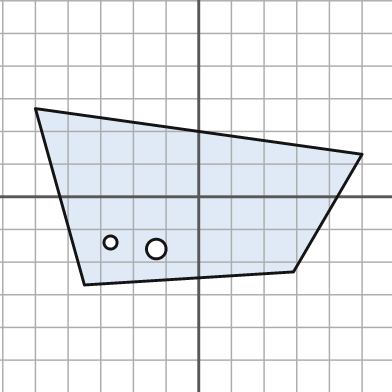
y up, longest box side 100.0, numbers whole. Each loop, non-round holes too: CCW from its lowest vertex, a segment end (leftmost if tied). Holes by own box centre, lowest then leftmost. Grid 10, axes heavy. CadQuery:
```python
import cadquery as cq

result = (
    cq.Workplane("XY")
    .moveTo(-35.0, -27.0)
    .lineTo(29.0, -23.0)
    .lineTo(50.0, 13.0)
    .lineTo(-50.0, 27.0)
    .close()
    .moveTo(-13.0, -16.0)
    .circle(3.0)
    .moveTo(-27.0, -14.0)
    .circle(2.0)
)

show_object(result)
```